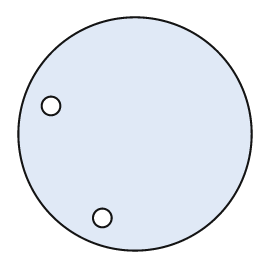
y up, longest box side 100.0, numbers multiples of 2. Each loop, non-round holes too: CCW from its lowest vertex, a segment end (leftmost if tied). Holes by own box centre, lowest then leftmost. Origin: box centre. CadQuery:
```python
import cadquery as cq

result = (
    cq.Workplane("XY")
    .moveTo(0.0, 0.0)
    .circle(50.0)
    .moveTo(-14.0, -36.0)
    .circle(4.0)
    .moveTo(-36.0, 12.0)
    .circle(4.0)
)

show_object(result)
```